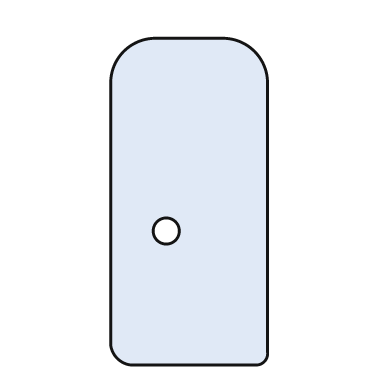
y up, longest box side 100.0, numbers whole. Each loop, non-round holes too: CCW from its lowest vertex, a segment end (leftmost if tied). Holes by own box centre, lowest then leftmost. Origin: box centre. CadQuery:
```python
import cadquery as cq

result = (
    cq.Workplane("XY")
    .moveTo(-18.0, -50.0)
    .lineTo(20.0, -50.0)
    .threePointArc((23.0, -49.0), (24.0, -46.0))
    .lineTo(24.0, 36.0)
    .threePointArc((20.0, 46.0), (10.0, 50.0))
    .lineTo(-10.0, 50.0)
    .threePointArc((-20.0, 46.0), (-24.0, 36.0))
    .lineTo(-24.0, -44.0)
    .threePointArc((-22.0, -48.0), (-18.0, -50.0))
    .close()
    .moveTo(-7.0, -9.0)
    .circle(4.0)
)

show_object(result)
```